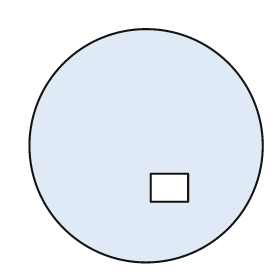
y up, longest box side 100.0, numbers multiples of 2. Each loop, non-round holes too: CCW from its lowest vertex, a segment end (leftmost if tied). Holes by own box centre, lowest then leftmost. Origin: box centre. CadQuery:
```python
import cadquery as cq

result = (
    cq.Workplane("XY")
    .moveTo(0.0, 0.0)
    .circle(50.0)
    .moveTo(2.0, -24.0)
    .lineTo(18.0, -24.0)
    .lineTo(18.0, -12.0)
    .lineTo(2.0, -12.0)
    .close()
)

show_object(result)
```